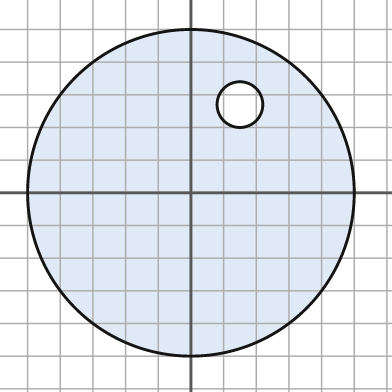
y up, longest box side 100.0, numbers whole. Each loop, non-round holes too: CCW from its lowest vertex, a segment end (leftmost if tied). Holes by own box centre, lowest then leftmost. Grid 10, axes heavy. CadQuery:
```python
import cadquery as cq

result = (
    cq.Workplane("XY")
    .moveTo(0.0, 0.0)
    .circle(50.0)
    .moveTo(15.0, 27.0)
    .circle(7.0)
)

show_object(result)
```